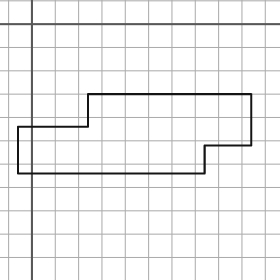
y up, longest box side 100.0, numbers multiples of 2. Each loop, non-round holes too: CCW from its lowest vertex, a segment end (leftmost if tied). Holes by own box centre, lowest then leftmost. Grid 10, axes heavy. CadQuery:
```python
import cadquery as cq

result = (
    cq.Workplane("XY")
    .moveTo(-6.0, -64.0)
    .lineTo(74.0, -64.0)
    .lineTo(74.0, -52.0)
    .lineTo(94.0, -52.0)
    .lineTo(94.0, -30.0)
    .lineTo(24.0, -30.0)
    .lineTo(24.0, -44.0)
    .lineTo(-6.0, -44.0)
    .close()
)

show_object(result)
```